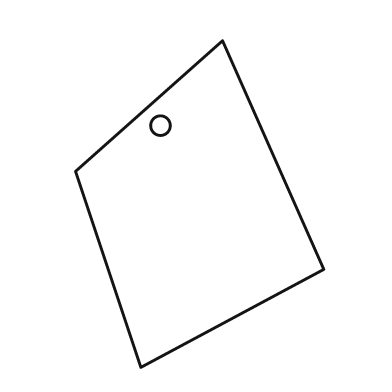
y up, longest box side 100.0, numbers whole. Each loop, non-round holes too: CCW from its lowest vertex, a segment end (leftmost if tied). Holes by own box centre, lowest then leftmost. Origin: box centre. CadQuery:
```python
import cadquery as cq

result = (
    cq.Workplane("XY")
    .moveTo(-18.0, -50.0)
    .lineTo(38.0, -20.0)
    .lineTo(7.0, 50.0)
    .lineTo(-38.0, 10.0)
    .close()
    .moveTo(-12.0, 24.0)
    .circle(3.0)
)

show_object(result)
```